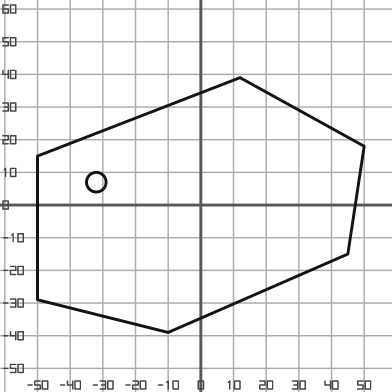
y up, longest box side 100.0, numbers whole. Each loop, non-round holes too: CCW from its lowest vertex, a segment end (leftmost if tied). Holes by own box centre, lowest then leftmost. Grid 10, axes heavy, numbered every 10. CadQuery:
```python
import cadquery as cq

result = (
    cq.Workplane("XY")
    .moveTo(-10.0, -39.0)
    .lineTo(45.0, -15.0)
    .lineTo(50.0, 18.0)
    .lineTo(12.0, 39.0)
    .lineTo(-50.0, 15.0)
    .lineTo(-50.0, -29.0)
    .close()
    .moveTo(-32.0, 7.0)
    .circle(3.0)
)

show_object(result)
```